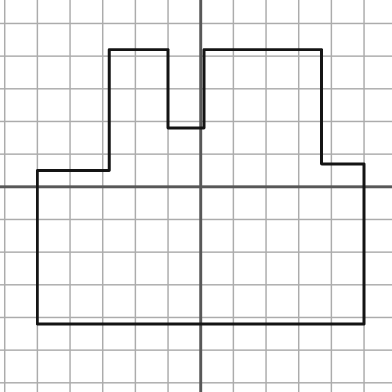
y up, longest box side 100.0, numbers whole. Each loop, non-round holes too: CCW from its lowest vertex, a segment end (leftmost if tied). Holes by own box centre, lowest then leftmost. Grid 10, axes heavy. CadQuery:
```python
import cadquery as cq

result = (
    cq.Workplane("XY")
    .moveTo(-50.0, -42.0)
    .lineTo(50.0, -42.0)
    .lineTo(50.0, 7.0)
    .lineTo(37.0, 7.0)
    .lineTo(37.0, 42.0)
    .lineTo(1.0, 42.0)
    .lineTo(1.0, 18.0)
    .lineTo(-10.0, 18.0)
    .lineTo(-10.0, 42.0)
    .lineTo(-28.0, 42.0)
    .lineTo(-28.0, 5.0)
    .lineTo(-50.0, 5.0)
    .close()
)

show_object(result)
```